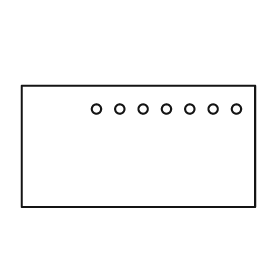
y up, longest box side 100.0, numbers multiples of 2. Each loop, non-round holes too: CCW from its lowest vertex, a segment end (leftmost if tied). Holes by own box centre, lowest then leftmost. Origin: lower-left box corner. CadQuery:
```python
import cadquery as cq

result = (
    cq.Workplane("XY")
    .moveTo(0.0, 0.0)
    .lineTo(100.0, 0.0)
    .lineTo(100.0, 52.0)
    .lineTo(0.0, 52.0)
    .close()
    .moveTo(32.0, 42.0)
    .circle(2.0)
    .moveTo(42.0, 42.0)
    .circle(2.0)
    .moveTo(52.0, 42.0)
    .circle(2.0)
    .moveTo(62.0, 42.0)
    .circle(2.0)
    .moveTo(72.0, 42.0)
    .circle(2.0)
    .moveTo(82.0, 42.0)
    .circle(2.0)
    .moveTo(92.0, 42.0)
    .circle(2.0)
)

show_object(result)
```